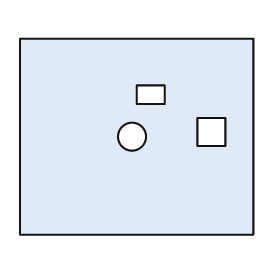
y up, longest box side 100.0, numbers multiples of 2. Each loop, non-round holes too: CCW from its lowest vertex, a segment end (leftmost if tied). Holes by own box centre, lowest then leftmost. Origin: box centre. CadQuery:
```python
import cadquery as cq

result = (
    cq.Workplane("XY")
    .moveTo(-50.0, -42.0)
    .lineTo(50.0, -42.0)
    .lineTo(50.0, 42.0)
    .lineTo(-50.0, 42.0)
    .close()
    .moveTo(-2.0, 0.0)
    .circle(6.0)
    .moveTo(26.0, -4.0)
    .lineTo(38.0, -4.0)
    .lineTo(38.0, 8.0)
    .lineTo(26.0, 8.0)
    .close()
    .moveTo(0.0, 14.0)
    .lineTo(12.0, 14.0)
    .lineTo(12.0, 22.0)
    .lineTo(0.0, 22.0)
    .close()
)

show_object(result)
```